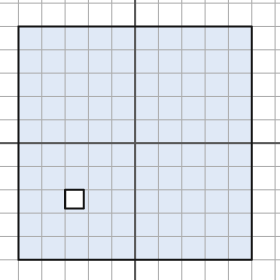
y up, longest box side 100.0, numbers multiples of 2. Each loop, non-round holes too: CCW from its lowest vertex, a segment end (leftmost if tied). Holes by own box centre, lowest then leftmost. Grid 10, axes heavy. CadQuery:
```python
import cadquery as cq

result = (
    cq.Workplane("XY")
    .moveTo(-50.0, -50.0)
    .lineTo(50.0, -50.0)
    .lineTo(50.0, 50.0)
    .lineTo(-50.0, 50.0)
    .close()
    .moveTo(-30.0, -28.0)
    .lineTo(-22.0, -28.0)
    .lineTo(-22.0, -20.0)
    .lineTo(-30.0, -20.0)
    .close()
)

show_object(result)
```